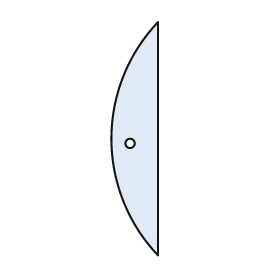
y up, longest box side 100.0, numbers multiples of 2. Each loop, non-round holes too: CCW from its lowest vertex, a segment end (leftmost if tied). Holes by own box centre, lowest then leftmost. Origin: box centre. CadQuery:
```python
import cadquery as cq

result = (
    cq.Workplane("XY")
    .moveTo(10.0, -50.0)
    .lineTo(10.0, 50.0)
    .threePointArc((-10.0, 0.0), (10.0, -50.0))
    .close()
    .moveTo(-2.0, -2.0)
    .circle(2.0)
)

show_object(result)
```